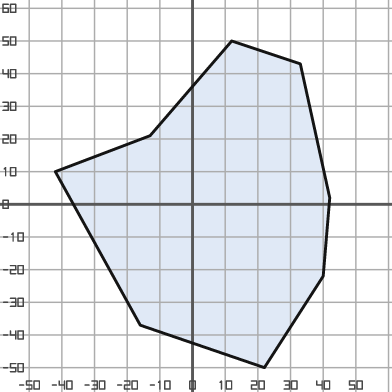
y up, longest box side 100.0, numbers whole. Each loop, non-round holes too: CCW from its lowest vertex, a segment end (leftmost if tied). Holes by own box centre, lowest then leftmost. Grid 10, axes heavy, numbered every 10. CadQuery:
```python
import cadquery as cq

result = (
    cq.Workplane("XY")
    .moveTo(22.0, -50.0)
    .lineTo(40.0, -22.0)
    .lineTo(42.0, 2.0)
    .lineTo(33.0, 43.0)
    .lineTo(12.0, 50.0)
    .lineTo(-13.0, 21.0)
    .lineTo(-42.0, 10.0)
    .lineTo(-16.0, -37.0)
    .close()
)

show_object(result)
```